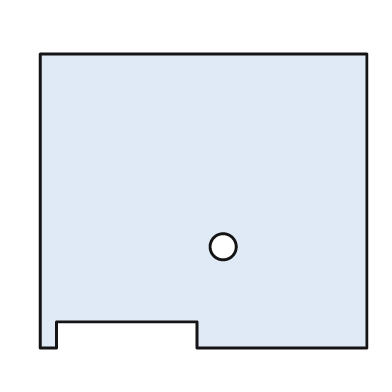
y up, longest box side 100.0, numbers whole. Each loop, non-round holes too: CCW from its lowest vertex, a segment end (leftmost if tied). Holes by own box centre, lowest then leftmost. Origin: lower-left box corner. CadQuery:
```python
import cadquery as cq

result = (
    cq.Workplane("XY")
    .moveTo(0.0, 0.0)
    .lineTo(5.0, 0.0)
    .lineTo(5.0, 8.0)
    .lineTo(48.0, 8.0)
    .lineTo(48.0, 0.0)
    .lineTo(100.0, 0.0)
    .lineTo(100.0, 90.0)
    .lineTo(0.0, 90.0)
    .close()
    .moveTo(56.0, 31.0)
    .circle(4.0)
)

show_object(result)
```